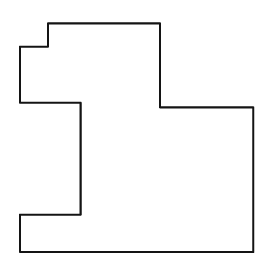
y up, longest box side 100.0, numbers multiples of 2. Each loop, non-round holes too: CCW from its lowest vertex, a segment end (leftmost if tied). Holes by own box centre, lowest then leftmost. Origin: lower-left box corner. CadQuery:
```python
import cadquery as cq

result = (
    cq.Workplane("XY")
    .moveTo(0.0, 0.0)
    .lineTo(100.0, 0.0)
    .lineTo(100.0, 62.0)
    .lineTo(60.0, 62.0)
    .lineTo(60.0, 98.0)
    .lineTo(12.0, 98.0)
    .lineTo(12.0, 88.0)
    .lineTo(0.0, 88.0)
    .lineTo(0.0, 64.0)
    .lineTo(26.0, 64.0)
    .lineTo(26.0, 16.0)
    .lineTo(0.0, 16.0)
    .close()
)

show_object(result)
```